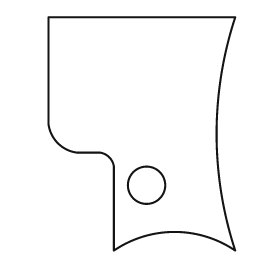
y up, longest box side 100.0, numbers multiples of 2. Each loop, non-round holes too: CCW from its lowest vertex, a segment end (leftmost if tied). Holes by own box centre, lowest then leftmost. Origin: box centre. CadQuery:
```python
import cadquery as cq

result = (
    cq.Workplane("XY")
    .moveTo(-12.0, -50.0)
    .threePointArc((14.0, -42.0), (40.0, -50.0))
    .threePointArc((32.0, 0.0), (40.0, 50.0))
    .lineTo(-40.0, 50.0)
    .lineTo(-40.0, 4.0)
    .threePointArc((-36.0, -4.0), (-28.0, -8.0))
    .lineTo(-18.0, -8.0)
    .threePointArc((-14.0, -10.0), (-12.0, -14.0))
    .close()
    .moveTo(2.0, -22.0)
    .circle(8.0)
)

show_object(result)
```